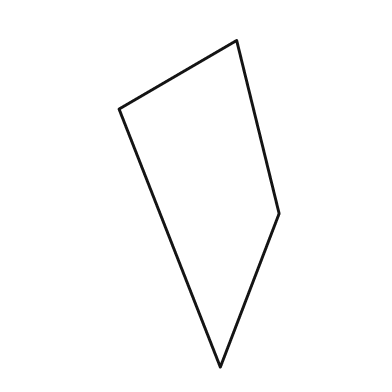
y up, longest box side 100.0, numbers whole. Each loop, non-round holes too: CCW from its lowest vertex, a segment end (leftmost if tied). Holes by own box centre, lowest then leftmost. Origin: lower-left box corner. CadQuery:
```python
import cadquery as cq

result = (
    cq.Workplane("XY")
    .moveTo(31.0, 0.0)
    .lineTo(49.0, 47.0)
    .lineTo(36.0, 100.0)
    .lineTo(0.0, 79.0)
    .close()
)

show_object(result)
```